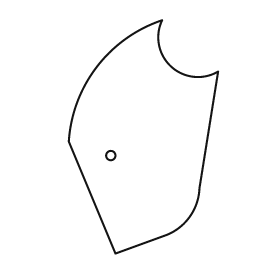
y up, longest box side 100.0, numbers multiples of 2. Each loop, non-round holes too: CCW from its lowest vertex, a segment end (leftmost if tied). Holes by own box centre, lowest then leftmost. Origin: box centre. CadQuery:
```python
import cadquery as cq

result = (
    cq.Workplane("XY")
    .moveTo(-12.0, -50.0)
    .lineTo(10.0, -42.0)
    .threePointArc((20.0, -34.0), (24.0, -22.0))
    .lineTo(32.0, 28.0)
    .threePointArc((12.0, 30.0), (8.0, 50.0))
    .threePointArc((-20.0, 30.0), (-32.0, -2.0))
    .close()
    .moveTo(-14.0, -8.0)
    .circle(2.0)
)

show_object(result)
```